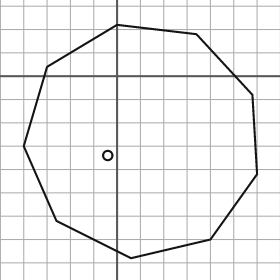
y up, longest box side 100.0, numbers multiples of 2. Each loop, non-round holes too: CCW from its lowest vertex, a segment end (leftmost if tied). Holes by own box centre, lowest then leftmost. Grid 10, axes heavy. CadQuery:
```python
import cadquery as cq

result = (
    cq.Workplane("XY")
    .moveTo(6.0, -78.0)
    .lineTo(40.0, -70.0)
    .lineTo(60.0, -42.0)
    .lineTo(58.0, -8.0)
    .lineTo(34.0, 18.0)
    .lineTo(0.0, 22.0)
    .lineTo(-30.0, 4.0)
    .lineTo(-40.0, -30.0)
    .lineTo(-26.0, -62.0)
    .close()
    .moveTo(-4.0, -34.0)
    .circle(2.0)
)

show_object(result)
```